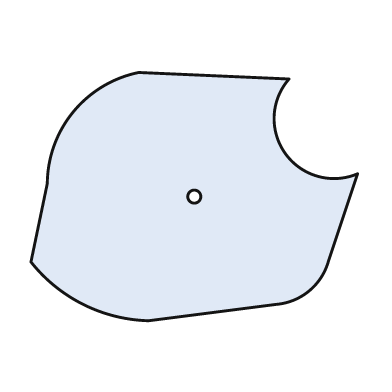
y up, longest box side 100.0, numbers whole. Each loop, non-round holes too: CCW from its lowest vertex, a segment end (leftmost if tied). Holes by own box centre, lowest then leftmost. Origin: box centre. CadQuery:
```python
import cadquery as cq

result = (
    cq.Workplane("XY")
    .moveTo(-14.0, -38.0)
    .lineTo(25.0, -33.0)
    .threePointArc((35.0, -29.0), (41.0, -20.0))
    .lineTo(50.0, 7.0)
    .threePointArc((28.0, 13.0), (29.0, 36.0))
    .lineTo(-17.0, 38.0)
    .threePointArc((-37.0, 26.0), (-45.0, 4.0))
    .lineTo(-50.0, -20.0)
    .threePointArc((-34.0, -33.0), (-14.0, -38.0))
    .close()
    .moveTo(0.0, 0.0)
    .circle(2.0)
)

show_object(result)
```